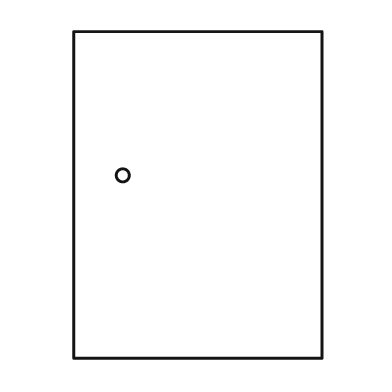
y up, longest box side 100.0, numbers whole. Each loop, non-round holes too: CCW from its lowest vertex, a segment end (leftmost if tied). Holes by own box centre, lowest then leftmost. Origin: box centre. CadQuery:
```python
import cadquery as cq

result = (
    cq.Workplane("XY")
    .moveTo(-38.0, -50.0)
    .lineTo(38.0, -50.0)
    .lineTo(38.0, 50.0)
    .lineTo(-38.0, 50.0)
    .close()
    .moveTo(-23.0, 6.0)
    .circle(2.0)
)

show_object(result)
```